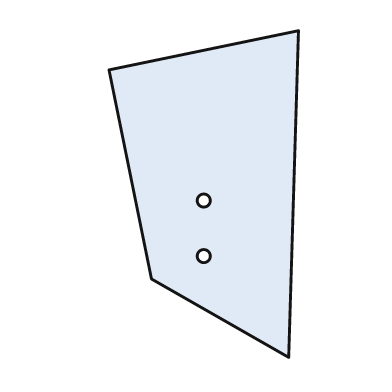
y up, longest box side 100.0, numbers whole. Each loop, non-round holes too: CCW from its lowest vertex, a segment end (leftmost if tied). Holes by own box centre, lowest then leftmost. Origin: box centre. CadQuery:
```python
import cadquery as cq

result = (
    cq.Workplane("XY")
    .moveTo(26.0, -50.0)
    .lineTo(29.0, 50.0)
    .lineTo(-29.0, 38.0)
    .lineTo(-16.0, -26.0)
    .close()
    .moveTo(0.0, -19.0)
    .circle(2.0)
    .moveTo(0.0, -2.0)
    .circle(2.0)
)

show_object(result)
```